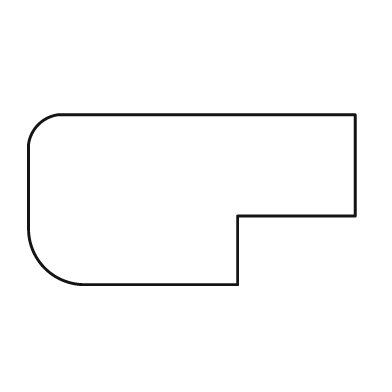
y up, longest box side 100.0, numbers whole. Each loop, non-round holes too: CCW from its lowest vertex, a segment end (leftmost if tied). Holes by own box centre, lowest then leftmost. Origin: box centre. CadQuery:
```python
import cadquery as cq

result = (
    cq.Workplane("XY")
    .moveTo(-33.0, -26.0)
    .lineTo(14.0, -26.0)
    .lineTo(14.0, -5.0)
    .lineTo(50.0, -5.0)
    .lineTo(50.0, 26.0)
    .lineTo(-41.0, 26.0)
    .threePointArc((-47.0, 23.0), (-50.0, 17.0))
    .lineTo(-50.0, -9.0)
    .threePointArc((-45.0, -21.0), (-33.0, -26.0))
    .close()
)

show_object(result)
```